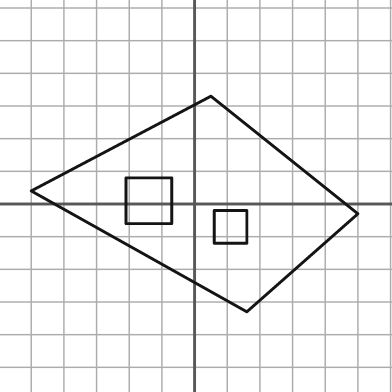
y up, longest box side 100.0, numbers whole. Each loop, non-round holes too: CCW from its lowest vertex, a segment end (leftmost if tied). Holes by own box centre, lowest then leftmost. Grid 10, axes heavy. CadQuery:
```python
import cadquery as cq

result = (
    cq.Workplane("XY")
    .moveTo(16.0, -33.0)
    .lineTo(50.0, -3.0)
    .lineTo(5.0, 33.0)
    .lineTo(-50.0, 4.0)
    .close()
    .moveTo(6.0, -12.0)
    .lineTo(16.0, -12.0)
    .lineTo(16.0, -2.0)
    .lineTo(6.0, -2.0)
    .close()
    .moveTo(-21.0, -6.0)
    .lineTo(-7.0, -6.0)
    .lineTo(-7.0, 8.0)
    .lineTo(-21.0, 8.0)
    .close()
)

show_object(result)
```